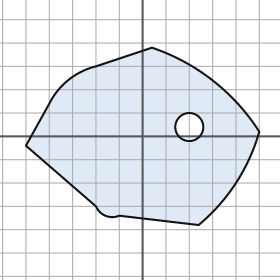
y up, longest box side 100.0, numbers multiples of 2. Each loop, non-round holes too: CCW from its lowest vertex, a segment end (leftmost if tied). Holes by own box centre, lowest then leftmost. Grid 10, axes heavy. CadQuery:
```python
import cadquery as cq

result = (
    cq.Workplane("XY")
    .moveTo(24.0, -38.0)
    .threePointArc((40.0, -20.0), (50.0, 2.0))
    .threePointArc((30.0, 24.0), (4.0, 38.0))
    .lineTo(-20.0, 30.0)
    .threePointArc((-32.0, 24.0), (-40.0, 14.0))
    .lineTo(-50.0, -4.0)
    .lineTo(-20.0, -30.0)
    .threePointArc((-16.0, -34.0), (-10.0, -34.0))
    .close()
    .moveTo(20.0, 4.0)
    .circle(6.0)
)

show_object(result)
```